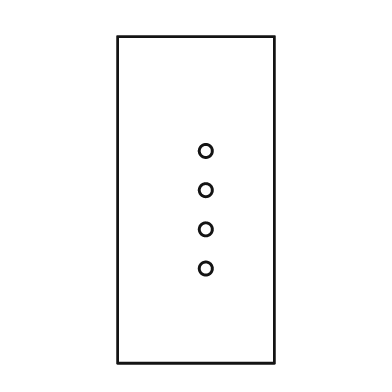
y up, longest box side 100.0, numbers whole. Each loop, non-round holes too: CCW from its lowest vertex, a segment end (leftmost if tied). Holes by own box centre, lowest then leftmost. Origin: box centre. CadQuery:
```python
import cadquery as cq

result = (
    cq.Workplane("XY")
    .moveTo(-24.0, -50.0)
    .lineTo(24.0, -50.0)
    .lineTo(24.0, 50.0)
    .lineTo(-24.0, 50.0)
    .close()
    .moveTo(3.0, -21.0)
    .circle(2.0)
    .moveTo(3.0, -9.0)
    .circle(2.0)
    .moveTo(3.0, 3.0)
    .circle(2.0)
    .moveTo(3.0, 15.0)
    .circle(2.0)
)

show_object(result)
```